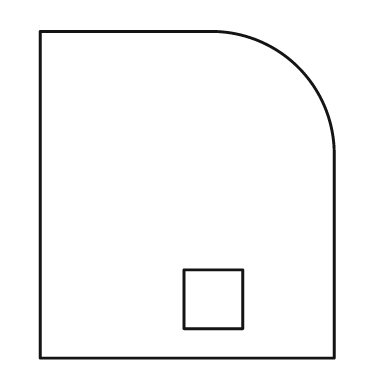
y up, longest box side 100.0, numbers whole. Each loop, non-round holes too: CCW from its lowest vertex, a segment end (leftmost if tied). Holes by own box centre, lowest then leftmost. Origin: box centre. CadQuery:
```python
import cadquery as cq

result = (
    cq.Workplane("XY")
    .moveTo(-45.0, -50.0)
    .lineTo(45.0, -50.0)
    .lineTo(45.0, 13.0)
    .threePointArc((34.0, 39.0), (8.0, 50.0))
    .lineTo(-45.0, 50.0)
    .close()
    .moveTo(-1.0, -41.0)
    .lineTo(17.0, -41.0)
    .lineTo(17.0, -23.0)
    .lineTo(-1.0, -23.0)
    .close()
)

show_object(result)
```